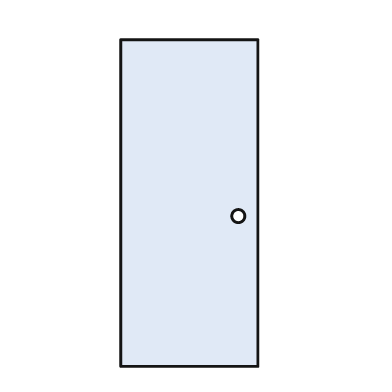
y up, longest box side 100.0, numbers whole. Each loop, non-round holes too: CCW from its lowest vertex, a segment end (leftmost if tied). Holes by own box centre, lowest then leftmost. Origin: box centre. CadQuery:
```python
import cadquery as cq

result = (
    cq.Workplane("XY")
    .moveTo(-21.0, -50.0)
    .lineTo(21.0, -50.0)
    .lineTo(21.0, 50.0)
    .lineTo(-21.0, 50.0)
    .close()
    .moveTo(15.0, -4.0)
    .circle(2.0)
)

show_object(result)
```